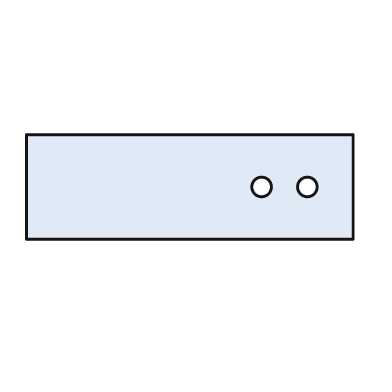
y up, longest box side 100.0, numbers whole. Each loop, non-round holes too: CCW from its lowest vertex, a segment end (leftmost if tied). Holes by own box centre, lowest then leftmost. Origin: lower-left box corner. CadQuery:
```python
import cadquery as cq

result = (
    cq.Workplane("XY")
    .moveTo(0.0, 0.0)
    .lineTo(100.0, 0.0)
    .lineTo(100.0, 32.0)
    .lineTo(0.0, 32.0)
    .close()
    .moveTo(72.0, 16.0)
    .circle(3.0)
    .moveTo(86.0, 16.0)
    .circle(3.0)
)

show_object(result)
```